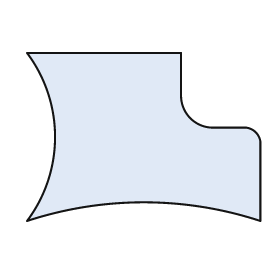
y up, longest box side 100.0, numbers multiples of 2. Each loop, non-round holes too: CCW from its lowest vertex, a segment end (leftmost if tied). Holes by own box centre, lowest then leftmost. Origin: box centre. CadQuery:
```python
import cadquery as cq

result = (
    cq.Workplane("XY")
    .moveTo(-50.0, -36.0)
    .threePointArc((0.0, -28.0), (50.0, -36.0))
    .lineTo(50.0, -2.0)
    .threePointArc((48.0, 2.0), (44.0, 4.0))
    .lineTo(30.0, 4.0)
    .threePointArc((20.0, 8.0), (16.0, 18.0))
    .lineTo(16.0, 36.0)
    .lineTo(-50.0, 36.0)
    .threePointArc((-38.0, 0.0), (-50.0, -36.0))
    .close()
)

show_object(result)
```